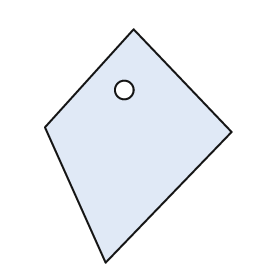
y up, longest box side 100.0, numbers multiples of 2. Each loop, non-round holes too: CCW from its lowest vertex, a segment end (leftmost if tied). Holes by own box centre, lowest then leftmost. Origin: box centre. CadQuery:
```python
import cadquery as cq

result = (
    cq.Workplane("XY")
    .moveTo(-14.0, -50.0)
    .lineTo(40.0, 6.0)
    .lineTo(-2.0, 50.0)
    .lineTo(-40.0, 8.0)
    .close()
    .moveTo(-6.0, 24.0)
    .circle(4.0)
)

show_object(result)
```